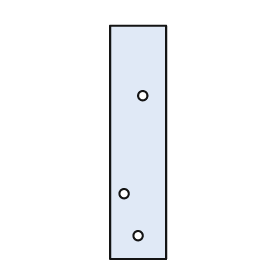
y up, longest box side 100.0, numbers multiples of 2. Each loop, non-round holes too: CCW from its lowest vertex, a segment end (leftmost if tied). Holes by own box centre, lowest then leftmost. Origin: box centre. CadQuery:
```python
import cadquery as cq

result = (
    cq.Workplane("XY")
    .moveTo(-12.0, -50.0)
    .lineTo(12.0, -50.0)
    .lineTo(12.0, 50.0)
    .lineTo(-12.0, 50.0)
    .close()
    .moveTo(0.0, -40.0)
    .circle(2.0)
    .moveTo(-6.0, -22.0)
    .circle(2.0)
    .moveTo(2.0, 20.0)
    .circle(2.0)
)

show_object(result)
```